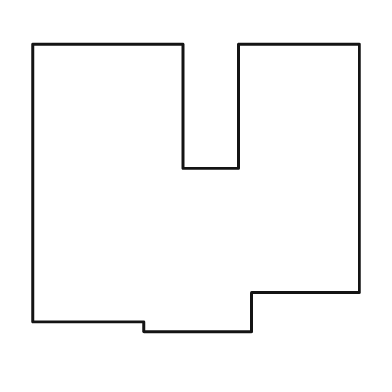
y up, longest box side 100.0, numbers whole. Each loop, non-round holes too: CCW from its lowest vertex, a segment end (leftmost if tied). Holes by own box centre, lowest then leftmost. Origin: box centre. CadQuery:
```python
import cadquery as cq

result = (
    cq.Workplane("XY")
    .moveTo(-16.0, -44.0)
    .lineTo(17.0, -44.0)
    .lineTo(17.0, -32.0)
    .lineTo(50.0, -32.0)
    .lineTo(50.0, 44.0)
    .lineTo(13.0, 44.0)
    .lineTo(13.0, 6.0)
    .lineTo(-4.0, 6.0)
    .lineTo(-4.0, 44.0)
    .lineTo(-50.0, 44.0)
    .lineTo(-50.0, -41.0)
    .lineTo(-16.0, -41.0)
    .close()
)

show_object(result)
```